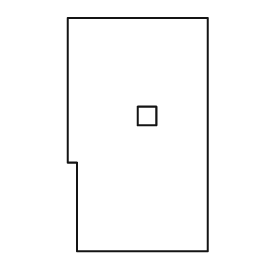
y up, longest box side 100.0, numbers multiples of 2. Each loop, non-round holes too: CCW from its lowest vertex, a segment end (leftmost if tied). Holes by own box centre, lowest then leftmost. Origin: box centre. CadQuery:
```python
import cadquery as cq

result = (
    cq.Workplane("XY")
    .moveTo(-26.0, -50.0)
    .lineTo(30.0, -50.0)
    .lineTo(30.0, 50.0)
    .lineTo(-30.0, 50.0)
    .lineTo(-30.0, -12.0)
    .lineTo(-26.0, -12.0)
    .close()
    .moveTo(0.0, 4.0)
    .lineTo(8.0, 4.0)
    .lineTo(8.0, 12.0)
    .lineTo(0.0, 12.0)
    .close()
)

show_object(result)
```